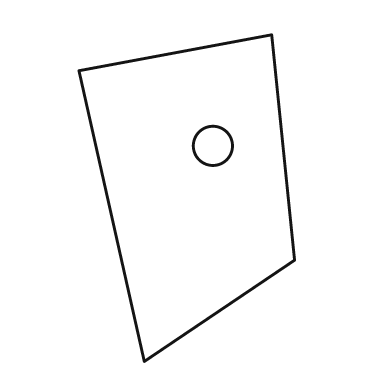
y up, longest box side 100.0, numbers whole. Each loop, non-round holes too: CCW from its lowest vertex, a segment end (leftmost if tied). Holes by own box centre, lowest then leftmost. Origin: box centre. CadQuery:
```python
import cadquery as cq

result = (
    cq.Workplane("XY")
    .moveTo(-13.0, -50.0)
    .lineTo(33.0, -19.0)
    .lineTo(26.0, 50.0)
    .lineTo(-33.0, 39.0)
    .close()
    .moveTo(8.0, 16.0)
    .circle(6.0)
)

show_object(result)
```